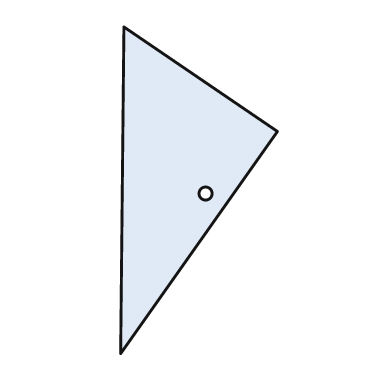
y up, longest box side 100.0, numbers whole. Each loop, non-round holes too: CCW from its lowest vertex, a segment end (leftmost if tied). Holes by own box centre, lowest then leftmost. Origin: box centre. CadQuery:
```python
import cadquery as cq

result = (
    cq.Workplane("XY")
    .moveTo(-24.0, -50.0)
    .lineTo(24.0, 18.0)
    .lineTo(-23.0, 50.0)
    .close()
    .moveTo(2.0, -1.0)
    .circle(2.0)
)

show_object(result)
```